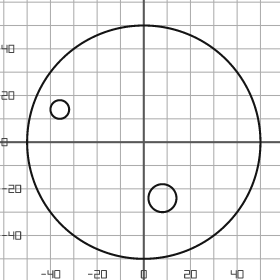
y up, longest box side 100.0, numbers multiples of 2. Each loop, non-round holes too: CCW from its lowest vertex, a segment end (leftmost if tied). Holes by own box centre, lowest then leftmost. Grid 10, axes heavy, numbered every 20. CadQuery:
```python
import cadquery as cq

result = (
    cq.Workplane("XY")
    .moveTo(0.0, 0.0)
    .circle(50.0)
    .moveTo(8.0, -24.0)
    .circle(6.0)
    .moveTo(-36.0, 14.0)
    .circle(4.0)
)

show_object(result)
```